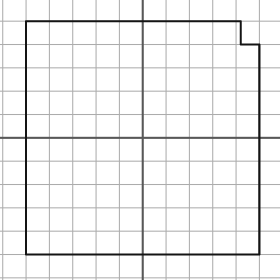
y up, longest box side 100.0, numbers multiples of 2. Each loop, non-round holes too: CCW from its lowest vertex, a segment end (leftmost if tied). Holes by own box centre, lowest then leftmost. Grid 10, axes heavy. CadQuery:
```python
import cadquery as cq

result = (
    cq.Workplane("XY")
    .moveTo(-50.0, -50.0)
    .lineTo(50.0, -50.0)
    .lineTo(50.0, 40.0)
    .lineTo(42.0, 40.0)
    .lineTo(42.0, 50.0)
    .lineTo(-50.0, 50.0)
    .close()
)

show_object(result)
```